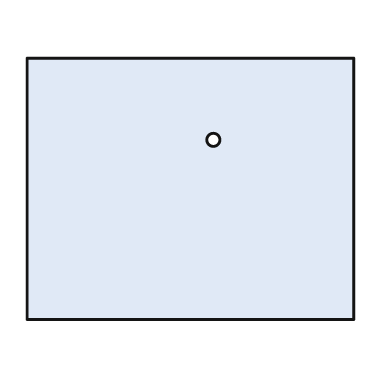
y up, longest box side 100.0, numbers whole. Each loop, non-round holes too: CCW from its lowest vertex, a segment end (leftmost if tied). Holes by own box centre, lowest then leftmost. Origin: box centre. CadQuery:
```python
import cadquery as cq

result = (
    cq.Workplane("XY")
    .moveTo(-50.0, -40.0)
    .lineTo(50.0, -40.0)
    .lineTo(50.0, 40.0)
    .lineTo(-50.0, 40.0)
    .close()
    .moveTo(7.0, 15.0)
    .circle(2.0)
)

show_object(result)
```